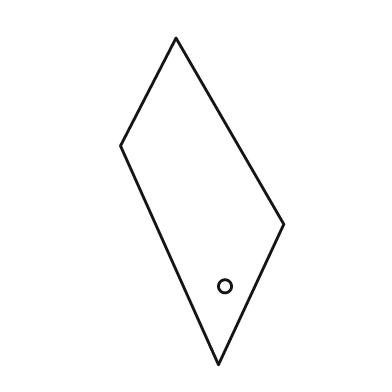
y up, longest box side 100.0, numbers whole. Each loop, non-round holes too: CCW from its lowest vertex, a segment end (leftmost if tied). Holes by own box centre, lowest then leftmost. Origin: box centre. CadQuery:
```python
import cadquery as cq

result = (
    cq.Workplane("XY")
    .moveTo(5.0, -50.0)
    .lineTo(25.0, -7.0)
    .lineTo(-8.0, 50.0)
    .lineTo(-25.0, 17.0)
    .close()
    .moveTo(7.0, -26.0)
    .circle(2.0)
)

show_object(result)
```